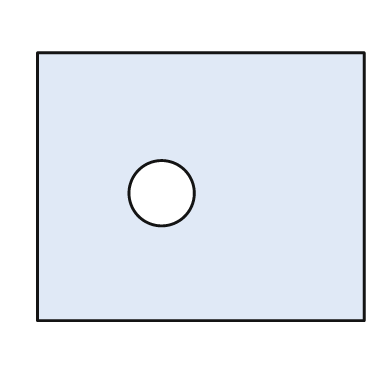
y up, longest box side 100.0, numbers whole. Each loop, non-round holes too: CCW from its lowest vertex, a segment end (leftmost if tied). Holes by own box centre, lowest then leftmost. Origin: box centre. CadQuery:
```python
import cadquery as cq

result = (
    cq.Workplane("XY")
    .moveTo(-50.0, -41.0)
    .lineTo(50.0, -41.0)
    .lineTo(50.0, 41.0)
    .lineTo(-50.0, 41.0)
    .close()
    .moveTo(-12.0, -2.0)
    .circle(10.0)
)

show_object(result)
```